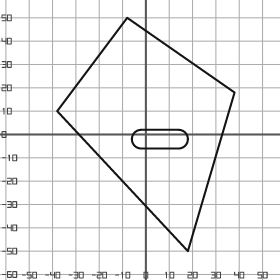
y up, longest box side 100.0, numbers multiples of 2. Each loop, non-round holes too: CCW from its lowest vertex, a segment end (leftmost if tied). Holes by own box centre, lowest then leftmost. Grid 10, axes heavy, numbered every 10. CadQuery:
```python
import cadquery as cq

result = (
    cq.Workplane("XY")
    .moveTo(18.0, -50.0)
    .lineTo(38.0, 18.0)
    .lineTo(-8.0, 50.0)
    .lineTo(-38.0, 10.0)
    .close()
    .moveTo(-2.0, -6.0)
    .lineTo(14.0, -6.0)
    .threePointArc((18.0, -2.0), (14.0, 2.0))
    .lineTo(-2.0, 2.0)
    .threePointArc((-6.0, -2.0), (-2.0, -6.0))
    .close()
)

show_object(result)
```